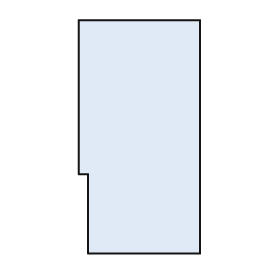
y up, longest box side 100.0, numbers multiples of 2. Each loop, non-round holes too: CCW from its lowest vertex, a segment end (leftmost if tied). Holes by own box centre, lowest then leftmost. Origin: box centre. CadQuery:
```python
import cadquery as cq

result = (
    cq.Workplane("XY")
    .moveTo(-22.0, -50.0)
    .lineTo(26.0, -50.0)
    .lineTo(26.0, 50.0)
    .lineTo(-26.0, 50.0)
    .lineTo(-26.0, -16.0)
    .lineTo(-22.0, -16.0)
    .close()
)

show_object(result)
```